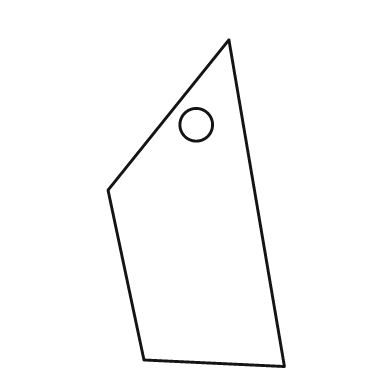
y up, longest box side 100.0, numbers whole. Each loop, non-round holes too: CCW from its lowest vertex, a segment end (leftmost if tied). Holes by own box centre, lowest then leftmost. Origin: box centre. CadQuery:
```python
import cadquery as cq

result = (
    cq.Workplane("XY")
    .moveTo(27.0, -50.0)
    .lineTo(10.0, 50.0)
    .lineTo(-27.0, 4.0)
    .lineTo(-16.0, -48.0)
    .close()
    .moveTo(0.0, 24.0)
    .circle(5.0)
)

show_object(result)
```